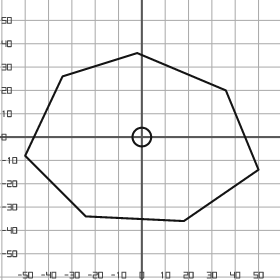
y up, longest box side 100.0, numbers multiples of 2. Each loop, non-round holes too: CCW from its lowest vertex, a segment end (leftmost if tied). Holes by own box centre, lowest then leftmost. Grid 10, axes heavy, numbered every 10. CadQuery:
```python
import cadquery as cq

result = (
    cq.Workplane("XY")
    .moveTo(18.0, -36.0)
    .lineTo(50.0, -14.0)
    .lineTo(36.0, 20.0)
    .lineTo(-2.0, 36.0)
    .lineTo(-34.0, 26.0)
    .lineTo(-50.0, -8.0)
    .lineTo(-24.0, -34.0)
    .close()
    .moveTo(0.0, 0.0)
    .circle(4.0)
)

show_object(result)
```